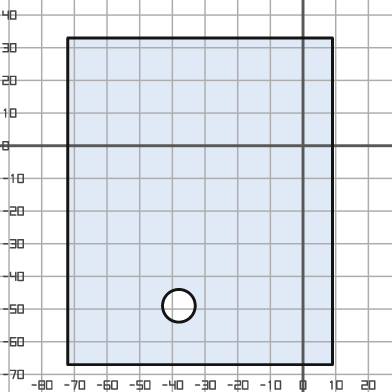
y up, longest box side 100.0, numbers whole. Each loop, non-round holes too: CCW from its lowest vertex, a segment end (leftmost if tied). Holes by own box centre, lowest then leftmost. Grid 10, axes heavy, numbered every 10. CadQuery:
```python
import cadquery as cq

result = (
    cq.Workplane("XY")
    .moveTo(-72.0, -67.0)
    .lineTo(9.0, -67.0)
    .lineTo(9.0, 33.0)
    .lineTo(-72.0, 33.0)
    .close()
    .moveTo(-38.0, -49.0)
    .circle(5.0)
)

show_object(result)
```